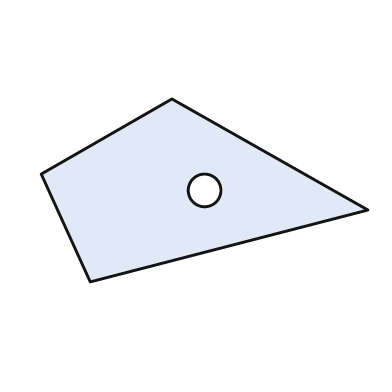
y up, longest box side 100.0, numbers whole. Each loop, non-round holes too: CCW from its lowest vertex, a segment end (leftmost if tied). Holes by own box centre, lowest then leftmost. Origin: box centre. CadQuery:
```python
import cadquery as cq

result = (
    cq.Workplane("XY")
    .moveTo(-35.0, -28.0)
    .lineTo(50.0, -6.0)
    .lineTo(-10.0, 28.0)
    .lineTo(-50.0, 5.0)
    .close()
    .moveTo(0.0, 0.0)
    .circle(5.0)
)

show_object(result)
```